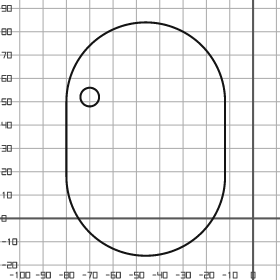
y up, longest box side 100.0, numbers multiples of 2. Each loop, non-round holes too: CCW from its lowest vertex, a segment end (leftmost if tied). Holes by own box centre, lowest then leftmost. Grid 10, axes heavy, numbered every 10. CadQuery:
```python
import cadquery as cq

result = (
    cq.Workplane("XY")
    .moveTo(-80.0, 18.0)
    .threePointArc((-46.0, -16.0), (-12.0, 18.0))
    .lineTo(-12.0, 50.0)
    .threePointArc((-46.0, 84.0), (-80.0, 50.0))
    .close()
    .moveTo(-70.0, 52.0)
    .circle(4.0)
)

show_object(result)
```